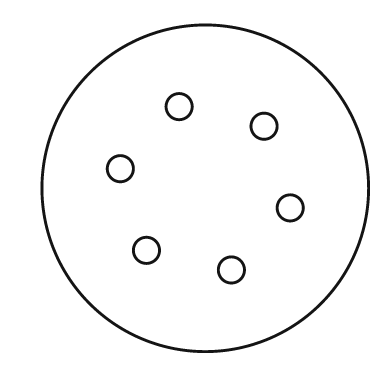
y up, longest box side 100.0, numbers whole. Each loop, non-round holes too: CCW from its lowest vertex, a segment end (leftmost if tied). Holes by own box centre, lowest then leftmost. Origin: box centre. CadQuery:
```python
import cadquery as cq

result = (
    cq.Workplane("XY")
    .moveTo(0.0, 0.0)
    .circle(50.0)
    .moveTo(8.0, -25.0)
    .circle(4.0)
    .moveTo(-18.0, -19.0)
    .circle(4.0)
    .moveTo(26.0, -6.0)
    .circle(4.0)
    .moveTo(-26.0, 6.0)
    .circle(4.0)
    .moveTo(18.0, 19.0)
    .circle(4.0)
    .moveTo(-8.0, 25.0)
    .circle(4.0)
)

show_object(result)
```